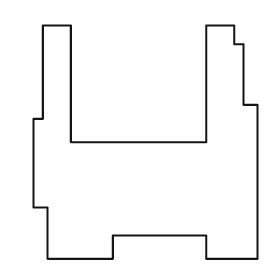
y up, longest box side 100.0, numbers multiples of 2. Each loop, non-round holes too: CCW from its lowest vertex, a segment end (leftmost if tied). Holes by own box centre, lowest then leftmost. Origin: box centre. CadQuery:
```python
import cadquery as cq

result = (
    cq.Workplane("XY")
    .moveTo(-42.0, -50.0)
    .lineTo(-14.0, -50.0)
    .lineTo(-14.0, -40.0)
    .lineTo(26.0, -40.0)
    .lineTo(26.0, -50.0)
    .lineTo(48.0, -50.0)
    .lineTo(48.0, 16.0)
    .lineTo(42.0, 16.0)
    .lineTo(42.0, 42.0)
    .lineTo(38.0, 42.0)
    .lineTo(38.0, 50.0)
    .lineTo(26.0, 50.0)
    .lineTo(26.0, 0.0)
    .lineTo(-32.0, 0.0)
    .lineTo(-32.0, 50.0)
    .lineTo(-44.0, 50.0)
    .lineTo(-44.0, 10.0)
    .lineTo(-48.0, 10.0)
    .lineTo(-48.0, -28.0)
    .lineTo(-42.0, -28.0)
    .close()
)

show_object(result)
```